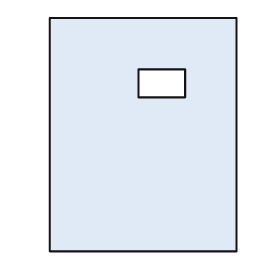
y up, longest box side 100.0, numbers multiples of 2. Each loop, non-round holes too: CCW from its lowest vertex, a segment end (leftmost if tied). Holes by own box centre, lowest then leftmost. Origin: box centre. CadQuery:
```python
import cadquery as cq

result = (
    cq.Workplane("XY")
    .moveTo(-40.0, -50.0)
    .lineTo(40.0, -50.0)
    .lineTo(40.0, 50.0)
    .lineTo(-40.0, 50.0)
    .close()
    .moveTo(-2.0, 16.0)
    .lineTo(18.0, 16.0)
    .lineTo(18.0, 28.0)
    .lineTo(-2.0, 28.0)
    .close()
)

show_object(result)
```